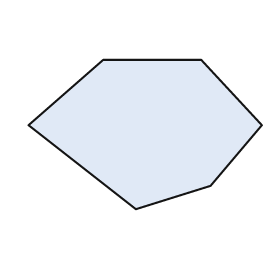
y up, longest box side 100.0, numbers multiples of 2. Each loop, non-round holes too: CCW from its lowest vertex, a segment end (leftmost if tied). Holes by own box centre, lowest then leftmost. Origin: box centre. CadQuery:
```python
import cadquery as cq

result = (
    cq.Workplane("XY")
    .moveTo(-4.0, -32.0)
    .lineTo(28.0, -22.0)
    .lineTo(50.0, 4.0)
    .lineTo(24.0, 32.0)
    .lineTo(-18.0, 32.0)
    .lineTo(-50.0, 4.0)
    .close()
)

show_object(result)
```